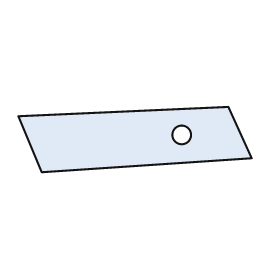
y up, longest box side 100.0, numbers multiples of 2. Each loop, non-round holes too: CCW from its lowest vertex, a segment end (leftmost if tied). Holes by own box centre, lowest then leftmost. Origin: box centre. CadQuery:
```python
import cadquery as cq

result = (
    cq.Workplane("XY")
    .moveTo(-40.0, -14.0)
    .lineTo(50.0, -8.0)
    .lineTo(40.0, 14.0)
    .lineTo(-50.0, 10.0)
    .close()
    .moveTo(20.0, 2.0)
    .circle(4.0)
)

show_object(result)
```